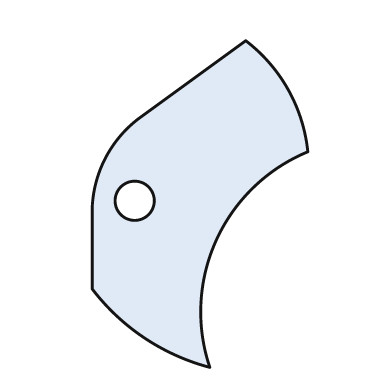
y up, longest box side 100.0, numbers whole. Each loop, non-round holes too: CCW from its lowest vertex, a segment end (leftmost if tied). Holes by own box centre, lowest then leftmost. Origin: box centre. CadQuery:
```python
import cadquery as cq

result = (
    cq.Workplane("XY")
    .moveTo(3.0, -50.0)
    .threePointArc((5.0, -11.0), (33.0, 16.0))
    .threePointArc((27.0, 35.0), (14.0, 50.0))
    .lineTo(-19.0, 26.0)
    .threePointArc((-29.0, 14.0), (-33.0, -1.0))
    .lineTo(-33.0, -26.0)
    .threePointArc((-17.0, -41.0), (3.0, -50.0))
    .close()
    .moveTo(-20.0, 1.0)
    .circle(6.0)
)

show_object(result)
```